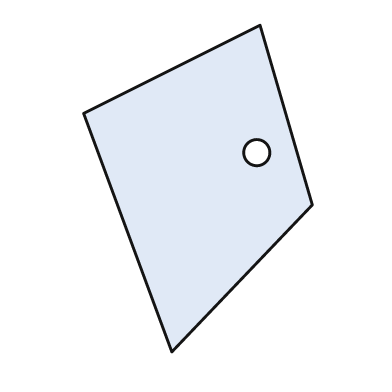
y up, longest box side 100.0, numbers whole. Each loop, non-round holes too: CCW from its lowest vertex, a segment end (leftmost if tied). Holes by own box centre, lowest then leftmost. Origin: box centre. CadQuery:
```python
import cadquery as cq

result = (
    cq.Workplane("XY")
    .moveTo(-8.0, -50.0)
    .lineTo(35.0, -5.0)
    .lineTo(19.0, 50.0)
    .lineTo(-35.0, 23.0)
    .close()
    .moveTo(18.0, 11.0)
    .circle(4.0)
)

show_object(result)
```